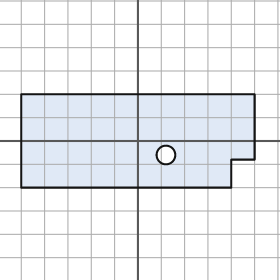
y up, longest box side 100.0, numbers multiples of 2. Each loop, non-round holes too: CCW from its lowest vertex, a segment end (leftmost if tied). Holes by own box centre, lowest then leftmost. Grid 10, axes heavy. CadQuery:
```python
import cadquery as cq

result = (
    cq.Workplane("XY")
    .moveTo(-50.0, -20.0)
    .lineTo(40.0, -20.0)
    .lineTo(40.0, -8.0)
    .lineTo(50.0, -8.0)
    .lineTo(50.0, 20.0)
    .lineTo(-50.0, 20.0)
    .close()
    .moveTo(12.0, -6.0)
    .circle(4.0)
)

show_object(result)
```